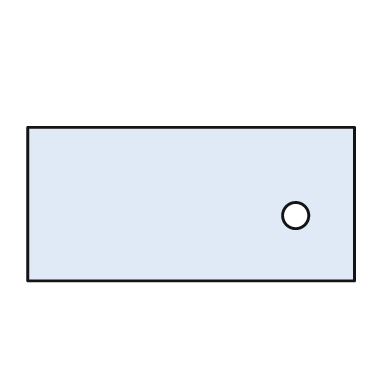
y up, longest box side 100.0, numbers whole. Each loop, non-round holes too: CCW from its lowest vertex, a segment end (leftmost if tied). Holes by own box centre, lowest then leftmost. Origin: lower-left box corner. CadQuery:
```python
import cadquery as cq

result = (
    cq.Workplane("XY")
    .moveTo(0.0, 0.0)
    .lineTo(100.0, 0.0)
    .lineTo(100.0, 47.0)
    .lineTo(0.0, 47.0)
    .close()
    .moveTo(82.0, 20.0)
    .circle(4.0)
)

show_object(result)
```